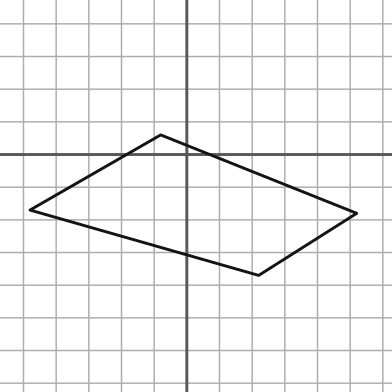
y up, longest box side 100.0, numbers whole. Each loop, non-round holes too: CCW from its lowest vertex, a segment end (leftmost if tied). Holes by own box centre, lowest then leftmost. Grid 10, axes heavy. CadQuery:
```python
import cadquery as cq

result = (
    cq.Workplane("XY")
    .moveTo(22.0, -37.0)
    .lineTo(52.0, -18.0)
    .lineTo(-8.0, 6.0)
    .lineTo(-48.0, -17.0)
    .close()
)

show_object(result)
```